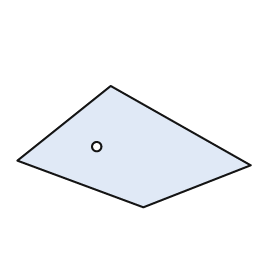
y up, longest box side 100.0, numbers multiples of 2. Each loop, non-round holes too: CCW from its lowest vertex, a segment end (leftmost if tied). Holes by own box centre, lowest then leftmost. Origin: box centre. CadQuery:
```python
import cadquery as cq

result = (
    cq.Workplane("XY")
    .moveTo(4.0, -26.0)
    .lineTo(50.0, -8.0)
    .lineTo(-10.0, 26.0)
    .lineTo(-50.0, -6.0)
    .close()
    .moveTo(-16.0, 0.0)
    .circle(2.0)
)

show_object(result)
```